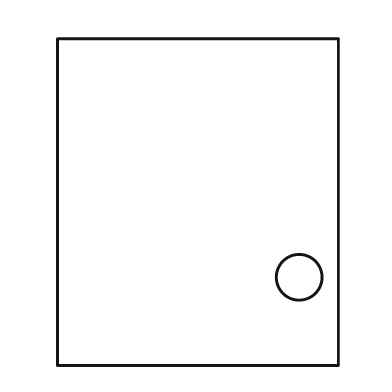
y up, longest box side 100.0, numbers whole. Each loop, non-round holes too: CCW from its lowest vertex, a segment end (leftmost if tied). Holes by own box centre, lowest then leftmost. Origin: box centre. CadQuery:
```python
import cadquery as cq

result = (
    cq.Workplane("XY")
    .moveTo(-43.0, -50.0)
    .lineTo(43.0, -50.0)
    .lineTo(43.0, 50.0)
    .lineTo(-43.0, 50.0)
    .close()
    .moveTo(31.0, -23.0)
    .circle(7.0)
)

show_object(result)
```